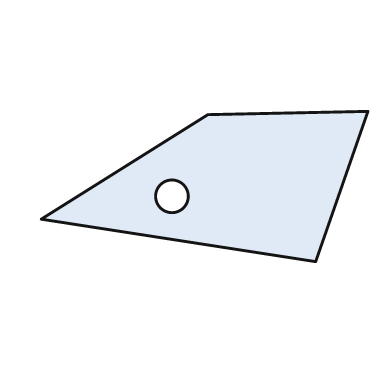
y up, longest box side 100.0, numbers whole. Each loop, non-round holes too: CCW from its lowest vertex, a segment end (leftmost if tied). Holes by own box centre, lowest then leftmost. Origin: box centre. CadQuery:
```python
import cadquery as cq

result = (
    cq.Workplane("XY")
    .moveTo(34.0, -23.0)
    .lineTo(50.0, 23.0)
    .lineTo(1.0, 22.0)
    .lineTo(-50.0, -10.0)
    .close()
    .moveTo(-10.0, -3.0)
    .circle(5.0)
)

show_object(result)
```